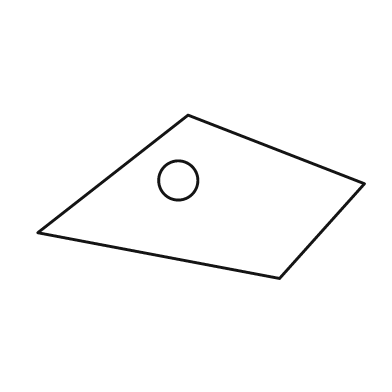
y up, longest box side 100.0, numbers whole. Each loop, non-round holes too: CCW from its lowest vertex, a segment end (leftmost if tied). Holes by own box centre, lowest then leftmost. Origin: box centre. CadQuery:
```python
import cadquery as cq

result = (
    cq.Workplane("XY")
    .moveTo(24.0, -25.0)
    .lineTo(50.0, 4.0)
    .lineTo(-4.0, 25.0)
    .lineTo(-50.0, -11.0)
    .close()
    .moveTo(-7.0, 5.0)
    .circle(6.0)
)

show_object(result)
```